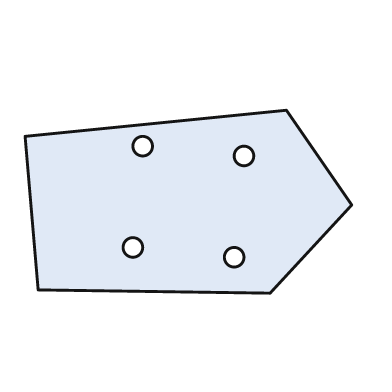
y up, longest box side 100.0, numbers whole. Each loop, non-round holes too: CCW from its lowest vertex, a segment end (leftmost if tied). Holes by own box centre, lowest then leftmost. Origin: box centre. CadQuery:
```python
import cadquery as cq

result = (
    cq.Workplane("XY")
    .moveTo(25.0, -28.0)
    .lineTo(50.0, -1.0)
    .lineTo(30.0, 28.0)
    .lineTo(-50.0, 20.0)
    .lineTo(-46.0, -27.0)
    .close()
    .moveTo(14.0, -17.0)
    .circle(3.0)
    .moveTo(-17.0, -14.0)
    .circle(3.0)
    .moveTo(17.0, 14.0)
    .circle(3.0)
    .moveTo(-14.0, 17.0)
    .circle(3.0)
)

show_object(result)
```